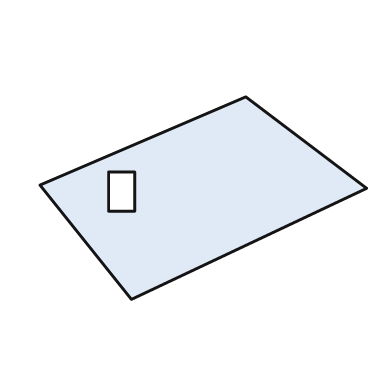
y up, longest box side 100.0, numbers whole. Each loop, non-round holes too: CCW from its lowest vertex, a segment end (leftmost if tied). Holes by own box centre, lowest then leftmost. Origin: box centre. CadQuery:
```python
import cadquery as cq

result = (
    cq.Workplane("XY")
    .moveTo(-22.0, -31.0)
    .lineTo(50.0, 3.0)
    .lineTo(13.0, 31.0)
    .lineTo(-50.0, 4.0)
    .close()
    .moveTo(-29.0, -4.0)
    .lineTo(-21.0, -4.0)
    .lineTo(-21.0, 8.0)
    .lineTo(-29.0, 8.0)
    .close()
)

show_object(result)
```